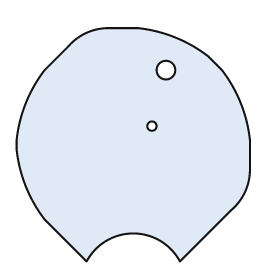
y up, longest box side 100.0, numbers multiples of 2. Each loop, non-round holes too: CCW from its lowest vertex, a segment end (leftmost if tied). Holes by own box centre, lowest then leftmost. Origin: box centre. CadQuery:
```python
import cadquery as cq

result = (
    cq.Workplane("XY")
    .moveTo(-20.0, -50.0)
    .threePointArc((0.0, -38.0), (20.0, -50.0))
    .lineTo(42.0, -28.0)
    .threePointArc((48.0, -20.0), (50.0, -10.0))
    .lineTo(50.0, 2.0)
    .threePointArc((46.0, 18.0), (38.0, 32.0))
    .lineTo(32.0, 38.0)
    .threePointArc((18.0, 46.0), (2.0, 50.0))
    .lineTo(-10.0, 50.0)
    .threePointArc((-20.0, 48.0), (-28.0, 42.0))
    .lineTo(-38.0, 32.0)
    .threePointArc((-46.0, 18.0), (-50.0, 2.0))
    .lineTo(-50.0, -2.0)
    .threePointArc((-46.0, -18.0), (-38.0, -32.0))
    .close()
    .moveTo(8.0, 8.0)
    .circle(2.0)
    .moveTo(14.0, 32.0)
    .circle(4.0)
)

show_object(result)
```